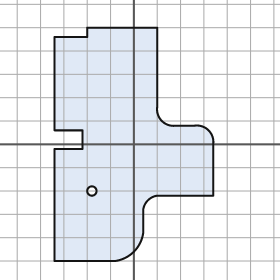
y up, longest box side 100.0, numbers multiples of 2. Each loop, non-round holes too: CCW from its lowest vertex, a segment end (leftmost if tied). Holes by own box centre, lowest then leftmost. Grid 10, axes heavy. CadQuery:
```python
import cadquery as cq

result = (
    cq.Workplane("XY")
    .moveTo(-34.0, -50.0)
    .lineTo(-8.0, -50.0)
    .threePointArc((0.0, -46.0), (4.0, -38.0))
    .lineTo(4.0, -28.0)
    .threePointArc((6.0, -24.0), (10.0, -22.0))
    .lineTo(34.0, -22.0)
    .lineTo(34.0, 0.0)
    .threePointArc((32.0, 6.0), (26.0, 8.0))
    .lineTo(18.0, 8.0)
    .threePointArc((12.0, 10.0), (10.0, 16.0))
    .lineTo(10.0, 50.0)
    .lineTo(-20.0, 50.0)
    .lineTo(-20.0, 46.0)
    .lineTo(-34.0, 46.0)
    .lineTo(-34.0, 6.0)
    .lineTo(-22.0, 6.0)
    .lineTo(-22.0, -2.0)
    .lineTo(-34.0, -2.0)
    .close()
    .moveTo(-18.0, -20.0)
    .circle(2.0)
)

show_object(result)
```